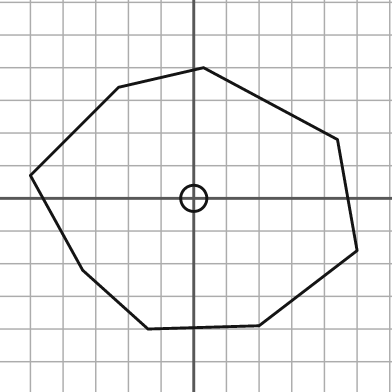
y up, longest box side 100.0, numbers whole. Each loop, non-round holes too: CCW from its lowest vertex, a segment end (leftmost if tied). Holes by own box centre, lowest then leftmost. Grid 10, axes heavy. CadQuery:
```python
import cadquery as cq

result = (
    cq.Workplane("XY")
    .moveTo(-14.0, -40.0)
    .lineTo(20.0, -39.0)
    .lineTo(50.0, -16.0)
    .lineTo(44.0, 18.0)
    .lineTo(3.0, 40.0)
    .lineTo(-23.0, 34.0)
    .lineTo(-50.0, 7.0)
    .lineTo(-34.0, -22.0)
    .close()
    .moveTo(0.0, 0.0)
    .circle(4.0)
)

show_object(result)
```